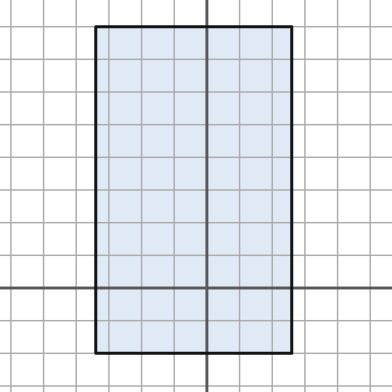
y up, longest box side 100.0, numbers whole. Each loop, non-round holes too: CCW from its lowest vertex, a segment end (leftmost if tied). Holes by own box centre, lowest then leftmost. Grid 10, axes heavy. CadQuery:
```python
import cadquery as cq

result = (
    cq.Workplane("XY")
    .moveTo(-34.0, -20.0)
    .lineTo(26.0, -20.0)
    .lineTo(26.0, 80.0)
    .lineTo(-34.0, 80.0)
    .close()
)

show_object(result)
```